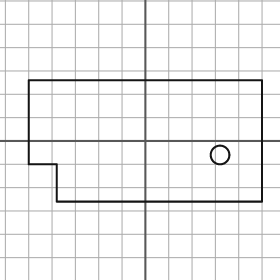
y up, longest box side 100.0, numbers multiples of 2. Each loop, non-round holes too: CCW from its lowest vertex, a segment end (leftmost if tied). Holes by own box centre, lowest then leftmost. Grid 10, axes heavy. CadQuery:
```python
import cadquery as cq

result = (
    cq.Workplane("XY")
    .moveTo(-38.0, -26.0)
    .lineTo(50.0, -26.0)
    .lineTo(50.0, 26.0)
    .lineTo(-50.0, 26.0)
    .lineTo(-50.0, -10.0)
    .lineTo(-38.0, -10.0)
    .close()
    .moveTo(32.0, -6.0)
    .circle(4.0)
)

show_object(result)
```